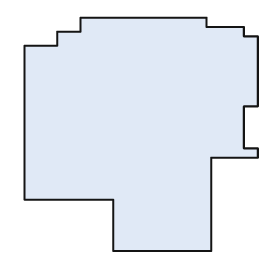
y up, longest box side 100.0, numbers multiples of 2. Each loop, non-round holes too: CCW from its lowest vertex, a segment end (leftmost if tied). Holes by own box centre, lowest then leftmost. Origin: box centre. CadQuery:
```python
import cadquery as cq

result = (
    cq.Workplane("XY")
    .moveTo(-12.0, -50.0)
    .lineTo(30.0, -50.0)
    .lineTo(30.0, -10.0)
    .lineTo(50.0, -10.0)
    .lineTo(50.0, -6.0)
    .lineTo(44.0, -6.0)
    .lineTo(44.0, 12.0)
    .lineTo(50.0, 12.0)
    .lineTo(50.0, 42.0)
    .lineTo(44.0, 42.0)
    .lineTo(44.0, 46.0)
    .lineTo(28.0, 46.0)
    .lineTo(28.0, 50.0)
    .lineTo(-26.0, 50.0)
    .lineTo(-26.0, 44.0)
    .lineTo(-36.0, 44.0)
    .lineTo(-36.0, 38.0)
    .lineTo(-50.0, 38.0)
    .lineTo(-50.0, -28.0)
    .lineTo(-12.0, -28.0)
    .close()
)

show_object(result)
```